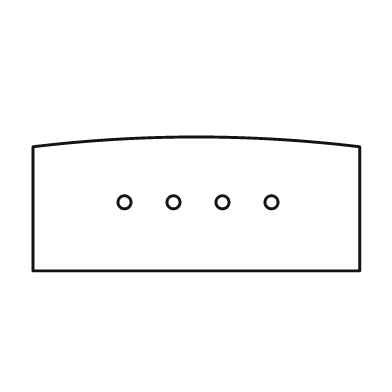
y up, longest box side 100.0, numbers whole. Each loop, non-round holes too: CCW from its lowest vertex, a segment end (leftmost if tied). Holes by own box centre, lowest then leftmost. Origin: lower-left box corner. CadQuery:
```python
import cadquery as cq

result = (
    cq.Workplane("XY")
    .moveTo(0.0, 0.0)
    .lineTo(100.0, 0.0)
    .lineTo(100.0, 38.0)
    .threePointArc((50.0, 41.0), (0.0, 38.0))
    .close()
    .moveTo(28.0, 21.0)
    .circle(2.0)
    .moveTo(43.0, 21.0)
    .circle(2.0)
    .moveTo(58.0, 21.0)
    .circle(2.0)
    .moveTo(73.0, 21.0)
    .circle(2.0)
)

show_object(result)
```